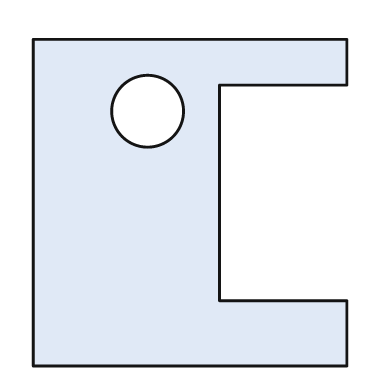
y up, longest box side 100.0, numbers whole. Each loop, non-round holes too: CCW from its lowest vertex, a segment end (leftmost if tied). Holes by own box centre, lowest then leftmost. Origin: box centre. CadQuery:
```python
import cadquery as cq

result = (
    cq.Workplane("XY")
    .moveTo(-48.0, -50.0)
    .lineTo(48.0, -50.0)
    .lineTo(48.0, -30.0)
    .lineTo(9.0, -30.0)
    .lineTo(9.0, 36.0)
    .lineTo(48.0, 36.0)
    .lineTo(48.0, 50.0)
    .lineTo(-48.0, 50.0)
    .close()
    .moveTo(-13.0, 28.0)
    .circle(11.0)
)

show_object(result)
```